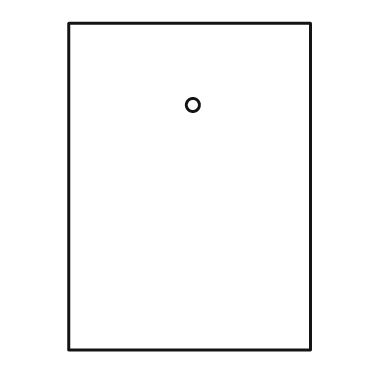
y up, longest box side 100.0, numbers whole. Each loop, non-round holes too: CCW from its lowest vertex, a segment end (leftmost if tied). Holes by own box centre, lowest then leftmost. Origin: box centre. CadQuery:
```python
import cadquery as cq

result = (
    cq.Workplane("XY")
    .moveTo(-37.0, -50.0)
    .lineTo(37.0, -50.0)
    .lineTo(37.0, 50.0)
    .lineTo(-37.0, 50.0)
    .close()
    .moveTo(1.0, 25.0)
    .circle(2.0)
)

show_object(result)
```